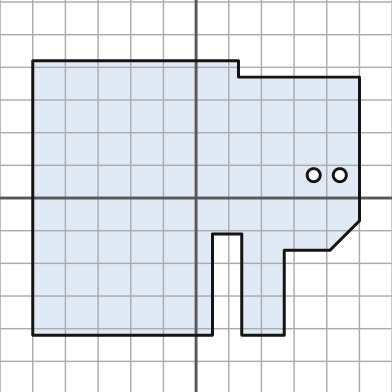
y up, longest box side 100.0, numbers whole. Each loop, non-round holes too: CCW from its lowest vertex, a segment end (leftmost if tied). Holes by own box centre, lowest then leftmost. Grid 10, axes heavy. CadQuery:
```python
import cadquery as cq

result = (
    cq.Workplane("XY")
    .moveTo(-50.0, -42.0)
    .lineTo(5.0, -42.0)
    .lineTo(5.0, -11.0)
    .lineTo(14.0, -11.0)
    .lineTo(14.0, -42.0)
    .lineTo(27.0, -42.0)
    .lineTo(27.0, -16.0)
    .lineTo(41.0, -16.0)
    .lineTo(50.0, -7.0)
    .lineTo(50.0, 37.0)
    .lineTo(13.0, 37.0)
    .lineTo(13.0, 42.0)
    .lineTo(-50.0, 42.0)
    .close()
    .moveTo(36.0, 7.0)
    .circle(2.0)
    .moveTo(44.0, 7.0)
    .circle(2.0)
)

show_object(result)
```